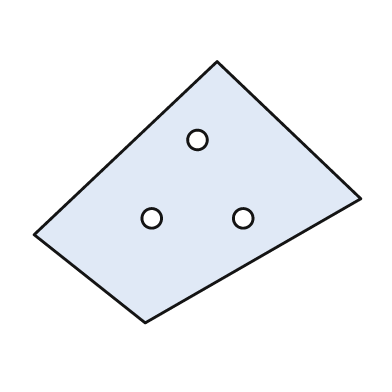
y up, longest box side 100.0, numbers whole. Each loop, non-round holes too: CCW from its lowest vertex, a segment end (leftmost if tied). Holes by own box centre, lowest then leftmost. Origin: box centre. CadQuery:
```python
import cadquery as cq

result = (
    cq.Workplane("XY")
    .moveTo(-16.0, -40.0)
    .lineTo(50.0, -2.0)
    .lineTo(6.0, 40.0)
    .lineTo(-50.0, -13.0)
    .close()
    .moveTo(-14.0, -8.0)
    .circle(3.0)
    .moveTo(14.0, -8.0)
    .circle(3.0)
    .moveTo(0.0, 16.0)
    .circle(3.0)
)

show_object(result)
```